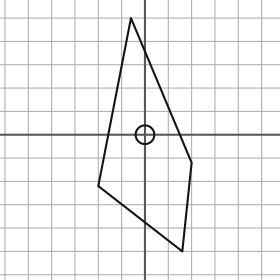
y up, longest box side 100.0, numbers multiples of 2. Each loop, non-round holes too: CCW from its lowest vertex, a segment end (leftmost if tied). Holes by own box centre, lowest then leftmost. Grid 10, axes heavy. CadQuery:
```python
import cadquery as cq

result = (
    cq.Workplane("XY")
    .moveTo(16.0, -50.0)
    .lineTo(20.0, -12.0)
    .lineTo(-6.0, 50.0)
    .lineTo(-20.0, -22.0)
    .close()
    .moveTo(0.0, 0.0)
    .circle(4.0)
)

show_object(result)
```